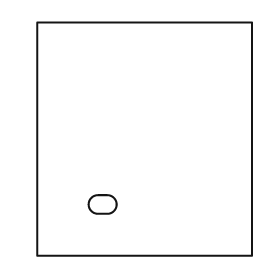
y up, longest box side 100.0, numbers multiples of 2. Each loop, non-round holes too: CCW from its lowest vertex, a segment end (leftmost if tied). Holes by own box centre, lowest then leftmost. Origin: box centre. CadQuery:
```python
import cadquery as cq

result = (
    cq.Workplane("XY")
    .moveTo(-46.0, -50.0)
    .lineTo(46.0, -50.0)
    .lineTo(46.0, 50.0)
    .lineTo(-46.0, 50.0)
    .close()
    .moveTo(-20.0, -32.0)
    .lineTo(-16.0, -32.0)
    .threePointArc((-12.0, -28.0), (-16.0, -24.0))
    .lineTo(-20.0, -24.0)
    .threePointArc((-24.0, -28.0), (-20.0, -32.0))
    .close()
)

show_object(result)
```